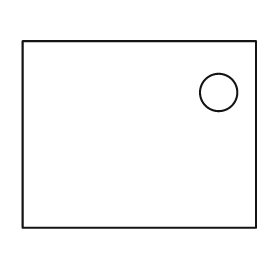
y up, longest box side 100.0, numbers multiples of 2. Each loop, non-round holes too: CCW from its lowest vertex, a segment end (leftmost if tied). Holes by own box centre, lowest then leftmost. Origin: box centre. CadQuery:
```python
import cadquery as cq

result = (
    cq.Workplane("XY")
    .moveTo(-50.0, -40.0)
    .lineTo(50.0, -40.0)
    .lineTo(50.0, 40.0)
    .lineTo(-50.0, 40.0)
    .close()
    .moveTo(34.0, 18.0)
    .circle(8.0)
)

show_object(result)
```